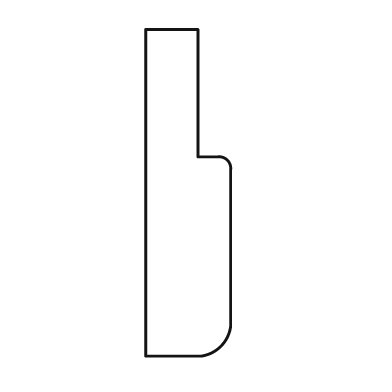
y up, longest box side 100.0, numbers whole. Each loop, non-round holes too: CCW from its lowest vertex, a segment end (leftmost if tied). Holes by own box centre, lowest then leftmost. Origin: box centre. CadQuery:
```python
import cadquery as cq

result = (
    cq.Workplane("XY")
    .moveTo(-13.0, -50.0)
    .lineTo(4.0, -50.0)
    .threePointArc((10.0, -47.0), (13.0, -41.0))
    .lineTo(13.0, 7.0)
    .threePointArc((12.0, 10.0), (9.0, 11.0))
    .lineTo(3.0, 11.0)
    .lineTo(3.0, 50.0)
    .lineTo(-13.0, 50.0)
    .close()
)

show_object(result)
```